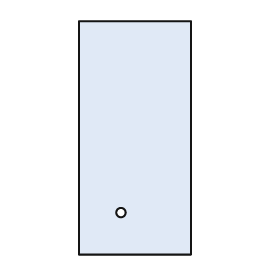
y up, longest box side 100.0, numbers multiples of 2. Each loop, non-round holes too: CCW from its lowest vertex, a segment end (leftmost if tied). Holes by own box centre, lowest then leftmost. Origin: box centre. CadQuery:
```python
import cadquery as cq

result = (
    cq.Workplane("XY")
    .moveTo(-24.0, -50.0)
    .lineTo(24.0, -50.0)
    .lineTo(24.0, 50.0)
    .lineTo(-24.0, 50.0)
    .close()
    .moveTo(-6.0, -32.0)
    .circle(2.0)
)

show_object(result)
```